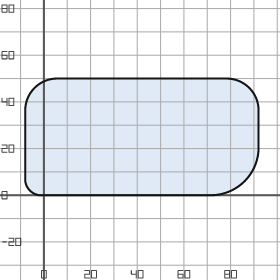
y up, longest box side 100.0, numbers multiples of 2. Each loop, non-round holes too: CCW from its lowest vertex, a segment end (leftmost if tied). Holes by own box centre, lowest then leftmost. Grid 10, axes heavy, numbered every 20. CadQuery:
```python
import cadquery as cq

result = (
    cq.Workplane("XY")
    .moveTo(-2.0, 0.0)
    .lineTo(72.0, 0.0)
    .threePointArc((86.0, 6.0), (92.0, 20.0))
    .lineTo(92.0, 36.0)
    .threePointArc((88.0, 46.0), (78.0, 50.0))
    .lineTo(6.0, 50.0)
    .threePointArc((-4.0, 46.0), (-8.0, 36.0))
    .lineTo(-8.0, 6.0)
    .threePointArc((-6.0, 2.0), (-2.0, 0.0))
    .close()
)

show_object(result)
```